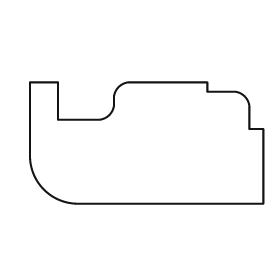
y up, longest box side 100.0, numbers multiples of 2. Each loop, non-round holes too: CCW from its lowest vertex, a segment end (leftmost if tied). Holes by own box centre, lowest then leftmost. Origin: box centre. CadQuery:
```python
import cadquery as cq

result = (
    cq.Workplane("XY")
    .moveTo(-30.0, -26.0)
    .lineTo(50.0, -26.0)
    .lineTo(50.0, 6.0)
    .lineTo(44.0, 6.0)
    .lineTo(44.0, 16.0)
    .threePointArc((42.0, 20.0), (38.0, 22.0))
    .lineTo(26.0, 22.0)
    .lineTo(26.0, 26.0)
    .lineTo(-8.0, 26.0)
    .threePointArc((-12.0, 24.0), (-14.0, 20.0))
    .lineTo(-14.0, 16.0)
    .threePointArc((-16.0, 12.0), (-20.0, 10.0))
    .lineTo(-38.0, 10.0)
    .lineTo(-38.0, 26.0)
    .lineTo(-50.0, 26.0)
    .lineTo(-50.0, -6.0)
    .threePointArc((-44.0, -20.0), (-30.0, -26.0))
    .close()
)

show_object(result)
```